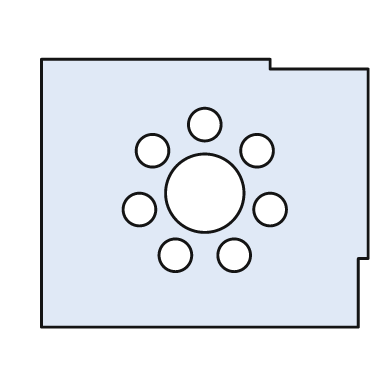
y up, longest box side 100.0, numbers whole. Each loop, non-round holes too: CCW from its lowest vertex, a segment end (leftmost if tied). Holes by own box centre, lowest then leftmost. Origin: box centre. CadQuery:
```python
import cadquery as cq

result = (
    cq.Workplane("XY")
    .moveTo(-50.0, -41.0)
    .lineTo(47.0, -41.0)
    .lineTo(47.0, -20.0)
    .lineTo(50.0, -20.0)
    .lineTo(50.0, 38.0)
    .lineTo(20.0, 38.0)
    .lineTo(20.0, 41.0)
    .lineTo(-50.0, 41.0)
    .close()
    .moveTo(-9.0, -19.0)
    .circle(5.0)
    .moveTo(9.0, -19.0)
    .circle(5.0)
    .moveTo(-20.0, -5.0)
    .circle(5.0)
    .moveTo(20.0, -5.0)
    .circle(5.0)
    .moveTo(0.0, 0.0)
    .circle(12.0)
    .moveTo(-16.0, 13.0)
    .circle(5.0)
    .moveTo(16.0, 13.0)
    .circle(5.0)
    .moveTo(0.0, 21.0)
    .circle(5.0)
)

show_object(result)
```